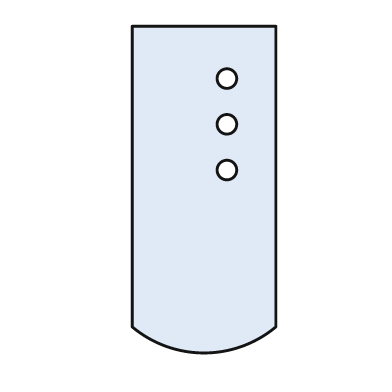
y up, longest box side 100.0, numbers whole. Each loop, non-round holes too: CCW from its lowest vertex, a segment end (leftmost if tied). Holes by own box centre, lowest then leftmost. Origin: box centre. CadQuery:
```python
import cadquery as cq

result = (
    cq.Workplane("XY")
    .moveTo(-22.0, -42.0)
    .threePointArc((0.0, -50.0), (22.0, -42.0))
    .lineTo(22.0, 50.0)
    .lineTo(-22.0, 50.0)
    .close()
    .moveTo(7.0, 6.0)
    .circle(3.0)
    .moveTo(7.0, 20.0)
    .circle(3.0)
    .moveTo(7.0, 34.0)
    .circle(3.0)
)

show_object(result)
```